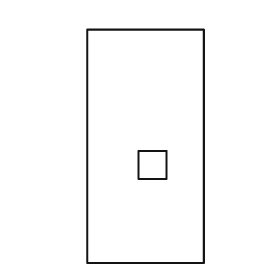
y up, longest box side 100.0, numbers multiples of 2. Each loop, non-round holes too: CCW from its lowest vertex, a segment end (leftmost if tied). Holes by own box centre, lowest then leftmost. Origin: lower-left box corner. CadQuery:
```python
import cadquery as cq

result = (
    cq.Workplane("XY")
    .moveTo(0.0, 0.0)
    .lineTo(50.0, 0.0)
    .lineTo(50.0, 100.0)
    .lineTo(0.0, 100.0)
    .close()
    .moveTo(22.0, 36.0)
    .lineTo(34.0, 36.0)
    .lineTo(34.0, 48.0)
    .lineTo(22.0, 48.0)
    .close()
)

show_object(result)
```